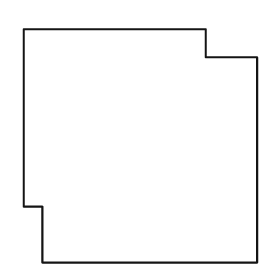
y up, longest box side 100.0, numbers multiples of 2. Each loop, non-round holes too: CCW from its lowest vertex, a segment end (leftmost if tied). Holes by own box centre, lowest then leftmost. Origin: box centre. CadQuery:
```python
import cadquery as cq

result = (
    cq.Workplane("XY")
    .moveTo(-42.0, -50.0)
    .lineTo(50.0, -50.0)
    .lineTo(50.0, 38.0)
    .lineTo(28.0, 38.0)
    .lineTo(28.0, 50.0)
    .lineTo(-50.0, 50.0)
    .lineTo(-50.0, -26.0)
    .lineTo(-42.0, -26.0)
    .close()
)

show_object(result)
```